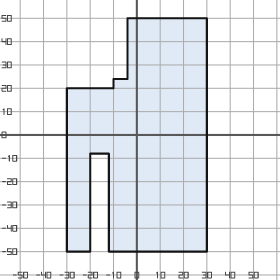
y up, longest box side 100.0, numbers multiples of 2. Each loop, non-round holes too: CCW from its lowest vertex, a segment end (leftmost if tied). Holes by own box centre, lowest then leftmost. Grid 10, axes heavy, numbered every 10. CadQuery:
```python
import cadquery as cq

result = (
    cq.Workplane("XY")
    .moveTo(-30.0, -50.0)
    .lineTo(-20.0, -50.0)
    .lineTo(-20.0, -8.0)
    .lineTo(-12.0, -8.0)
    .lineTo(-12.0, -50.0)
    .lineTo(30.0, -50.0)
    .lineTo(30.0, 50.0)
    .lineTo(-4.0, 50.0)
    .lineTo(-4.0, 24.0)
    .lineTo(-10.0, 24.0)
    .lineTo(-10.0, 20.0)
    .lineTo(-30.0, 20.0)
    .close()
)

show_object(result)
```